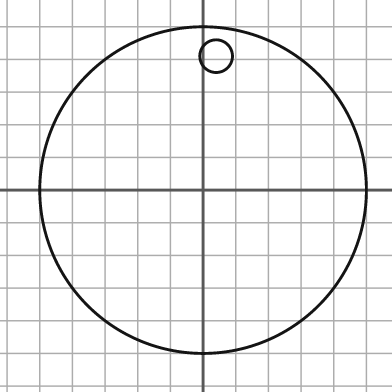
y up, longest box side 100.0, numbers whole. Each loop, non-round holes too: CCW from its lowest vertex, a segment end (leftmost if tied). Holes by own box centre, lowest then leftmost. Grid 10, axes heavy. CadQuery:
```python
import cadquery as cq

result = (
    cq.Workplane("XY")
    .moveTo(0.0, 0.0)
    .circle(50.0)
    .moveTo(4.0, 41.0)
    .circle(5.0)
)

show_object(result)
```